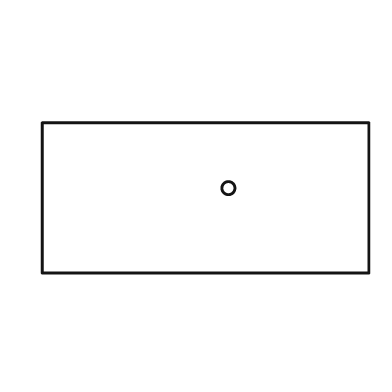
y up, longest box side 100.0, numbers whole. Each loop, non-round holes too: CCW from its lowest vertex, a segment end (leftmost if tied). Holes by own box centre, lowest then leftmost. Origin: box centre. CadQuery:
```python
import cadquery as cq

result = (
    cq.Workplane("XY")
    .moveTo(-50.0, -23.0)
    .lineTo(50.0, -23.0)
    .lineTo(50.0, 23.0)
    .lineTo(-50.0, 23.0)
    .close()
    .moveTo(7.0, 3.0)
    .circle(2.0)
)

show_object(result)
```